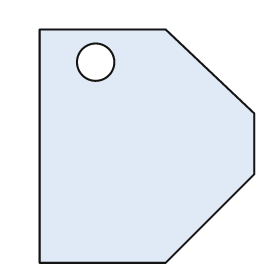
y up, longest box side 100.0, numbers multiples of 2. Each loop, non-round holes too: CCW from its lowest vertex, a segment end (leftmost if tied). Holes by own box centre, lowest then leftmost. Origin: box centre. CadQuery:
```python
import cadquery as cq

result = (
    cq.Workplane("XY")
    .moveTo(-46.0, -50.0)
    .lineTo(8.0, -50.0)
    .lineTo(46.0, -12.0)
    .lineTo(46.0, 14.0)
    .lineTo(8.0, 50.0)
    .lineTo(-46.0, 50.0)
    .close()
    .moveTo(-22.0, 36.0)
    .circle(8.0)
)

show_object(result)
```